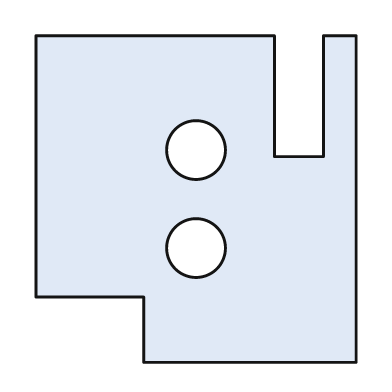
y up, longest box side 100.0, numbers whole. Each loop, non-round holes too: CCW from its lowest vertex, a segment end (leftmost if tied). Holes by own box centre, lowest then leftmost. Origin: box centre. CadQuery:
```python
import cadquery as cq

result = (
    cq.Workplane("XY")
    .moveTo(-16.0, -50.0)
    .lineTo(49.0, -50.0)
    .lineTo(49.0, 50.0)
    .lineTo(39.0, 50.0)
    .lineTo(39.0, 13.0)
    .lineTo(24.0, 13.0)
    .lineTo(24.0, 50.0)
    .lineTo(-49.0, 50.0)
    .lineTo(-49.0, -30.0)
    .lineTo(-16.0, -30.0)
    .close()
    .moveTo(0.0, -15.0)
    .circle(9.0)
    .moveTo(0.0, 15.0)
    .circle(9.0)
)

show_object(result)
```